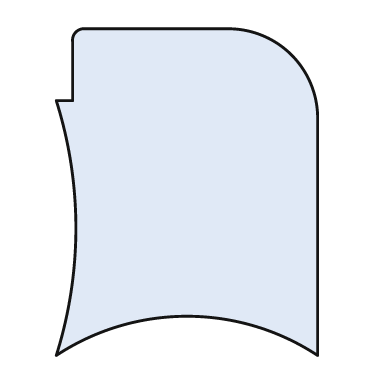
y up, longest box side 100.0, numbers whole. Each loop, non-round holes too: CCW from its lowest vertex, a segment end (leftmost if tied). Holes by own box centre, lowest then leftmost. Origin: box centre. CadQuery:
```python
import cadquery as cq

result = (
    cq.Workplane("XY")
    .moveTo(-40.0, -50.0)
    .threePointArc((0.0, -38.0), (40.0, -50.0))
    .lineTo(40.0, 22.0)
    .threePointArc((32.0, 42.0), (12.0, 50.0))
    .lineTo(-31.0, 50.0)
    .threePointArc((-34.0, 49.0), (-35.0, 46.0))
    .lineTo(-35.0, 28.0)
    .lineTo(-40.0, 28.0)
    .threePointArc((-34.0, -11.0), (-40.0, -50.0))
    .close()
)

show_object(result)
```